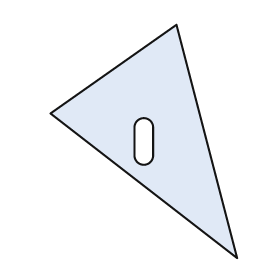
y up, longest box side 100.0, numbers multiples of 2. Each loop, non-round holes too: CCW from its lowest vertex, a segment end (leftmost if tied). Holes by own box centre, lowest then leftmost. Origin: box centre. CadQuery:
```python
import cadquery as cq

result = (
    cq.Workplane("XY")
    .moveTo(40.0, -50.0)
    .lineTo(14.0, 50.0)
    .lineTo(-40.0, 12.0)
    .close()
    .moveTo(-4.0, -6.0)
    .threePointArc((0.0, -10.0), (4.0, -6.0))
    .lineTo(4.0, 6.0)
    .threePointArc((0.0, 10.0), (-4.0, 6.0))
    .close()
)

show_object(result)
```